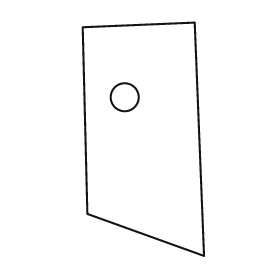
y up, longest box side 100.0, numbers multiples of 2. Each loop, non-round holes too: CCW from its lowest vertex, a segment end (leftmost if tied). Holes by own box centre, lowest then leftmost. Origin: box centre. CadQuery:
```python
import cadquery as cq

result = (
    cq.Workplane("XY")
    .moveTo(26.0, -50.0)
    .lineTo(22.0, 50.0)
    .lineTo(-26.0, 48.0)
    .lineTo(-24.0, -32.0)
    .close()
    .moveTo(-8.0, 18.0)
    .circle(6.0)
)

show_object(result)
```